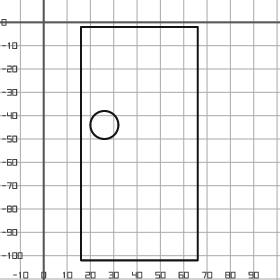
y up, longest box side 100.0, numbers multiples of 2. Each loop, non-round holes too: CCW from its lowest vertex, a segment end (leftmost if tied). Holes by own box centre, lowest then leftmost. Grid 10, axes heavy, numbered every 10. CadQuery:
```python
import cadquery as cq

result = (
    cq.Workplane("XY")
    .moveTo(16.0, -102.0)
    .lineTo(66.0, -102.0)
    .lineTo(66.0, -2.0)
    .lineTo(16.0, -2.0)
    .close()
    .moveTo(26.0, -44.0)
    .circle(6.0)
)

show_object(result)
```